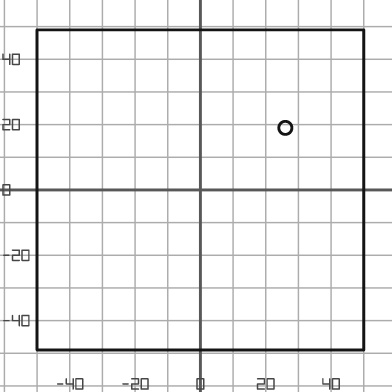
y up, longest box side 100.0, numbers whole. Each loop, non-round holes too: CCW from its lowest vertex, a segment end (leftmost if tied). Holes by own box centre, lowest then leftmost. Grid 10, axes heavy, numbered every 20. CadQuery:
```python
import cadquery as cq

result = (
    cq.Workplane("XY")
    .moveTo(-50.0, -49.0)
    .lineTo(50.0, -49.0)
    .lineTo(50.0, 49.0)
    .lineTo(-50.0, 49.0)
    .close()
    .moveTo(26.0, 19.0)
    .circle(2.0)
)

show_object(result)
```